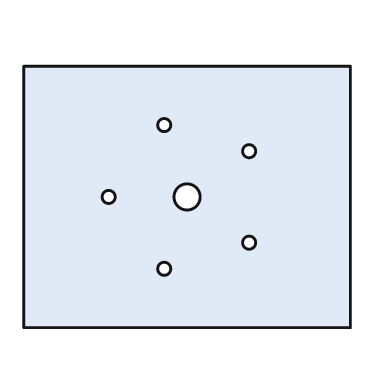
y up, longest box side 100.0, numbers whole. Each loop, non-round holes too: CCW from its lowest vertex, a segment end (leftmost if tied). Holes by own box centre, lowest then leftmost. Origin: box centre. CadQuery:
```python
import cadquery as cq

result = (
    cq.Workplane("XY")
    .moveTo(-50.0, -40.0)
    .lineTo(50.0, -40.0)
    .lineTo(50.0, 40.0)
    .lineTo(-50.0, 40.0)
    .close()
    .moveTo(-7.0, -22.0)
    .circle(2.0)
    .moveTo(19.0, -14.0)
    .circle(2.0)
    .moveTo(-24.0, 0.0)
    .circle(2.0)
    .moveTo(0.0, 0.0)
    .circle(4.0)
    .moveTo(19.0, 14.0)
    .circle(2.0)
    .moveTo(-7.0, 22.0)
    .circle(2.0)
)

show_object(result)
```